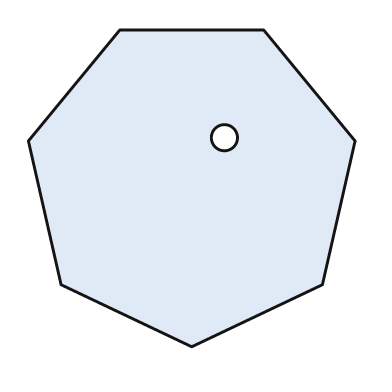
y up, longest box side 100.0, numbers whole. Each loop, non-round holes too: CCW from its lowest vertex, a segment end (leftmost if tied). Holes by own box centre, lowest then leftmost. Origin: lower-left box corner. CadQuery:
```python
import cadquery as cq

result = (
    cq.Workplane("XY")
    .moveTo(50.0, 0.0)
    .lineTo(90.0, 19.0)
    .lineTo(100.0, 63.0)
    .lineTo(72.0, 97.0)
    .lineTo(28.0, 97.0)
    .lineTo(0.0, 63.0)
    .lineTo(10.0, 19.0)
    .close()
    .moveTo(60.0, 64.0)
    .circle(4.0)
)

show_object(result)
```